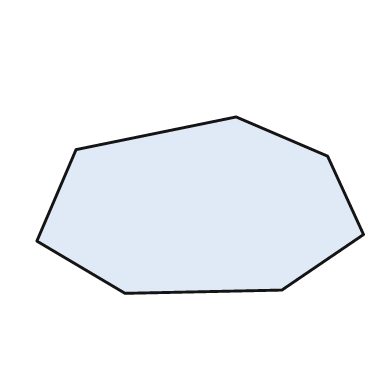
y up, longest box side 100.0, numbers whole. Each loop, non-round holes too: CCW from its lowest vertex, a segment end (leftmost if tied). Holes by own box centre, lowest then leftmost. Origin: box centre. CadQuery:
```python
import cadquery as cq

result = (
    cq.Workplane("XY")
    .moveTo(-23.0, -27.0)
    .lineTo(25.0, -26.0)
    .lineTo(50.0, -9.0)
    .lineTo(39.0, 15.0)
    .lineTo(11.0, 27.0)
    .lineTo(-38.0, 17.0)
    .lineTo(-50.0, -11.0)
    .close()
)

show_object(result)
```